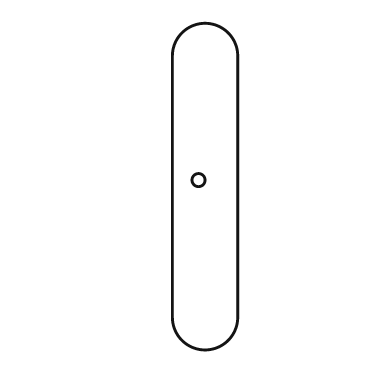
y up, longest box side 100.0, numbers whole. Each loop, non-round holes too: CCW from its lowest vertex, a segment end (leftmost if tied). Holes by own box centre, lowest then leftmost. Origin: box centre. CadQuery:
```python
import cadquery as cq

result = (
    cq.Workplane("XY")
    .moveTo(-10.0, -40.0)
    .threePointArc((0.0, -50.0), (10.0, -40.0))
    .lineTo(10.0, 40.0)
    .threePointArc((0.0, 50.0), (-10.0, 40.0))
    .close()
    .moveTo(-2.0, 2.0)
    .circle(2.0)
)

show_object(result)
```